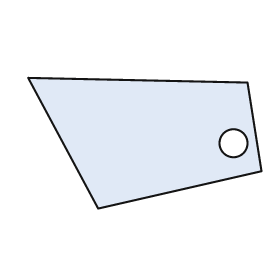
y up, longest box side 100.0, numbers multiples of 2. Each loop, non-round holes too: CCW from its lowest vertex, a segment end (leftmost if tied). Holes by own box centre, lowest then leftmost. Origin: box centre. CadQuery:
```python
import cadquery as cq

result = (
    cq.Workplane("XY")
    .moveTo(-20.0, -28.0)
    .lineTo(50.0, -12.0)
    .lineTo(44.0, 26.0)
    .lineTo(-50.0, 28.0)
    .close()
    .moveTo(38.0, 0.0)
    .circle(6.0)
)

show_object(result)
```